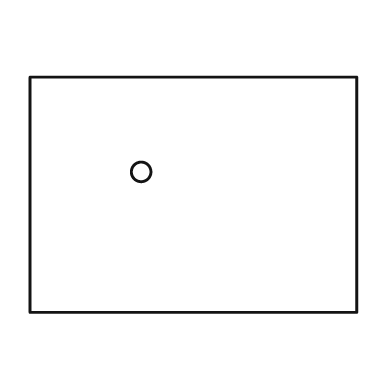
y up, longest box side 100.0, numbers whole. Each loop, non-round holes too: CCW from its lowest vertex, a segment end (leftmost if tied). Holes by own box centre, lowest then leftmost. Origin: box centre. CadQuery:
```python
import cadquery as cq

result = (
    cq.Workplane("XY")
    .moveTo(-50.0, -36.0)
    .lineTo(50.0, -36.0)
    .lineTo(50.0, 36.0)
    .lineTo(-50.0, 36.0)
    .close()
    .moveTo(-16.0, 7.0)
    .circle(3.0)
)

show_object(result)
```